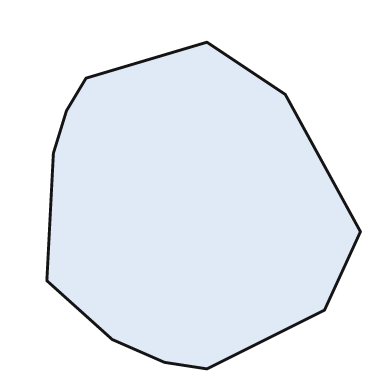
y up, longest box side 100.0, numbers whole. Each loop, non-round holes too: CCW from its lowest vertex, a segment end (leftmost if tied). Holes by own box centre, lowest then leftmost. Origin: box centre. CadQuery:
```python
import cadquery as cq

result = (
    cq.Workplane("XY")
    .moveTo(1.0, -50.0)
    .lineTo(37.0, -32.0)
    .lineTo(48.0, -8.0)
    .lineTo(25.0, 34.0)
    .lineTo(1.0, 50.0)
    .lineTo(-36.0, 39.0)
    .lineTo(-42.0, 29.0)
    .lineTo(-46.0, 16.0)
    .lineTo(-48.0, -23.0)
    .lineTo(-28.0, -41.0)
    .lineTo(-12.0, -48.0)
    .close()
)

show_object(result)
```